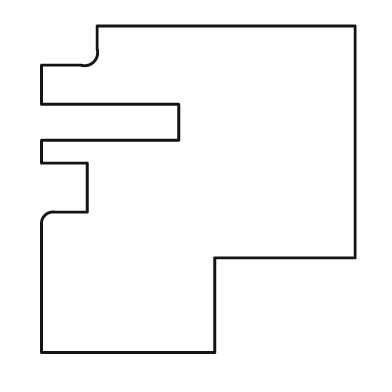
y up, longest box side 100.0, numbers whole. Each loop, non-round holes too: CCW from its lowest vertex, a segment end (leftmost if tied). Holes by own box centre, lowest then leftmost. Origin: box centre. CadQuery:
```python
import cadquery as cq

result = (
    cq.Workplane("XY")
    .moveTo(-48.0, -50.0)
    .lineTo(5.0, -50.0)
    .lineTo(5.0, -21.0)
    .lineTo(48.0, -21.0)
    .lineTo(48.0, 50.0)
    .lineTo(-31.0, 50.0)
    .lineTo(-31.0, 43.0)
    .threePointArc((-32.0, 39.0), (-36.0, 38.0))
    .lineTo(-48.0, 38.0)
    .lineTo(-48.0, 26.0)
    .lineTo(-6.0, 26.0)
    .lineTo(-6.0, 15.0)
    .lineTo(-48.0, 15.0)
    .lineTo(-48.0, 8.0)
    .lineTo(-34.0, 8.0)
    .lineTo(-34.0, -7.0)
    .lineTo(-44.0, -7.0)
    .threePointArc((-47.0, -8.0), (-48.0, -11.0))
    .close()
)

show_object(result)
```